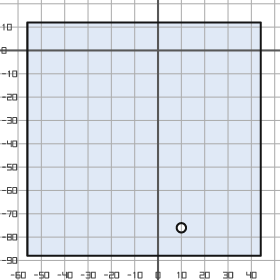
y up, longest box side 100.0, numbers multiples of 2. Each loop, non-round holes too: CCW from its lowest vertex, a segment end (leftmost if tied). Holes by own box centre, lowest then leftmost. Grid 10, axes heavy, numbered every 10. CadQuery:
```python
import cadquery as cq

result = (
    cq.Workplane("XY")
    .moveTo(-56.0, -88.0)
    .lineTo(44.0, -88.0)
    .lineTo(44.0, 12.0)
    .lineTo(-56.0, 12.0)
    .close()
    .moveTo(10.0, -76.0)
    .circle(2.0)
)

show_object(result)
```